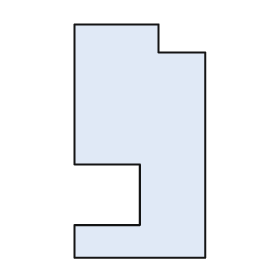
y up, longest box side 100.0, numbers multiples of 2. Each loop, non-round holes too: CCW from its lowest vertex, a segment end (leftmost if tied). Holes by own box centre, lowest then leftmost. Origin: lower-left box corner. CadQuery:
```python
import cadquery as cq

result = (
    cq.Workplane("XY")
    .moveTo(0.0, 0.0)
    .lineTo(56.0, 0.0)
    .lineTo(56.0, 88.0)
    .lineTo(36.0, 88.0)
    .lineTo(36.0, 100.0)
    .lineTo(0.0, 100.0)
    .lineTo(0.0, 40.0)
    .lineTo(28.0, 40.0)
    .lineTo(28.0, 14.0)
    .lineTo(0.0, 14.0)
    .close()
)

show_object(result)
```